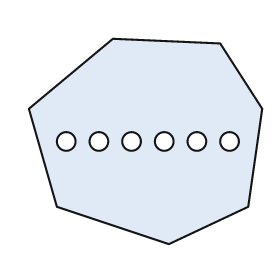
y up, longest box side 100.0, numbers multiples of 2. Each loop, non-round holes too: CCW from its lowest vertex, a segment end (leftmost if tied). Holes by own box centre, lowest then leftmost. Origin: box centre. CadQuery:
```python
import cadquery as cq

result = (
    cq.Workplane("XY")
    .moveTo(10.0, -44.0)
    .lineTo(44.0, -28.0)
    .lineTo(50.0, 14.0)
    .lineTo(32.0, 42.0)
    .lineTo(-14.0, 44.0)
    .lineTo(-50.0, 14.0)
    .lineTo(-38.0, -28.0)
    .close()
    .moveTo(-34.0, 0.0)
    .circle(4.0)
    .moveTo(-20.0, 0.0)
    .circle(4.0)
    .moveTo(-6.0, 0.0)
    .circle(4.0)
    .moveTo(8.0, 0.0)
    .circle(4.0)
    .moveTo(22.0, 0.0)
    .circle(4.0)
    .moveTo(36.0, 0.0)
    .circle(4.0)
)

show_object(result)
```